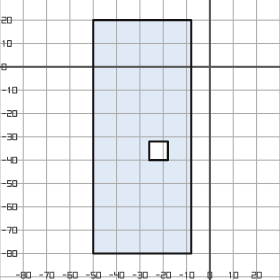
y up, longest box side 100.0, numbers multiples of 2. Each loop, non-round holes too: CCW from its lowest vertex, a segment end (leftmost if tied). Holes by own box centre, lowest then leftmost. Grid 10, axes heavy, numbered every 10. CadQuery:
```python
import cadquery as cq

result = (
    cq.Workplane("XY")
    .moveTo(-50.0, -80.0)
    .lineTo(-8.0, -80.0)
    .lineTo(-8.0, 20.0)
    .lineTo(-50.0, 20.0)
    .close()
    .moveTo(-26.0, -40.0)
    .lineTo(-18.0, -40.0)
    .lineTo(-18.0, -32.0)
    .lineTo(-26.0, -32.0)
    .close()
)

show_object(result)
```